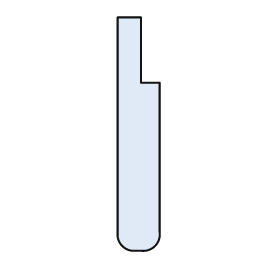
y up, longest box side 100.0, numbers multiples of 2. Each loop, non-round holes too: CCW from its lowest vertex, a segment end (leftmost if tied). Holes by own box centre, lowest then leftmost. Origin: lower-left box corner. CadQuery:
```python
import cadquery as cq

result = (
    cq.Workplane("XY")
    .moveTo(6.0, 0.0)
    .lineTo(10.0, 0.0)
    .threePointArc((16.0, 2.0), (18.0, 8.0))
    .lineTo(18.0, 72.0)
    .lineTo(10.0, 72.0)
    .lineTo(10.0, 100.0)
    .lineTo(0.0, 100.0)
    .lineTo(0.0, 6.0)
    .threePointArc((2.0, 2.0), (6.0, 0.0))
    .close()
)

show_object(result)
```